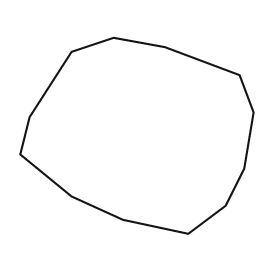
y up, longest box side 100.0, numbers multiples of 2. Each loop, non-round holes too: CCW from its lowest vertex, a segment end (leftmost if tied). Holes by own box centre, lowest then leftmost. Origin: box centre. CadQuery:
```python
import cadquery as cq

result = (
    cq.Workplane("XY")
    .moveTo(22.0, -42.0)
    .lineTo(38.0, -30.0)
    .lineTo(46.0, -14.0)
    .lineTo(50.0, 10.0)
    .lineTo(44.0, 26.0)
    .lineTo(12.0, 38.0)
    .lineTo(-10.0, 42.0)
    .lineTo(-28.0, 36.0)
    .lineTo(-46.0, 8.0)
    .lineTo(-50.0, -8.0)
    .lineTo(-28.0, -26.0)
    .lineTo(-6.0, -36.0)
    .close()
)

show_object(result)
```